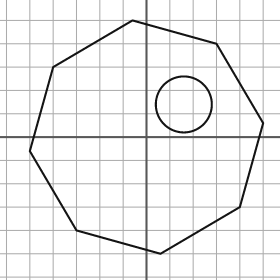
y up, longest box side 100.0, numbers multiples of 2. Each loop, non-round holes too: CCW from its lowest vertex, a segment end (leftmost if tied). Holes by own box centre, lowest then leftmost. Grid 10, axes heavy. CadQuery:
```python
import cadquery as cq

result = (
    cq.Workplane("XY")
    .moveTo(6.0, -50.0)
    .lineTo(40.0, -30.0)
    .lineTo(50.0, 6.0)
    .lineTo(30.0, 40.0)
    .lineTo(-6.0, 50.0)
    .lineTo(-40.0, 30.0)
    .lineTo(-50.0, -6.0)
    .lineTo(-30.0, -40.0)
    .close()
    .moveTo(16.0, 14.0)
    .circle(12.0)
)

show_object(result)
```